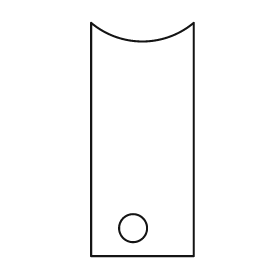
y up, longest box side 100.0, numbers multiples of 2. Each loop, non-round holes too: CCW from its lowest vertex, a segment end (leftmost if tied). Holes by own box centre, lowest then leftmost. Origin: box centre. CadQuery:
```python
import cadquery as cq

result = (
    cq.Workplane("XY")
    .moveTo(-22.0, -50.0)
    .lineTo(22.0, -50.0)
    .lineTo(22.0, 50.0)
    .threePointArc((0.0, 42.0), (-22.0, 50.0))
    .close()
    .moveTo(-4.0, -38.0)
    .circle(6.0)
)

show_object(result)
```